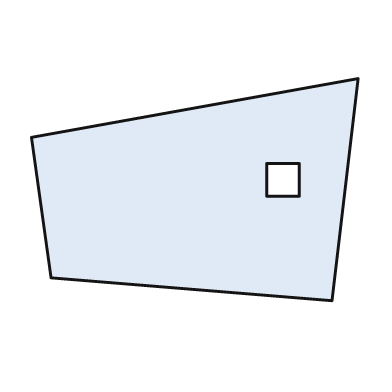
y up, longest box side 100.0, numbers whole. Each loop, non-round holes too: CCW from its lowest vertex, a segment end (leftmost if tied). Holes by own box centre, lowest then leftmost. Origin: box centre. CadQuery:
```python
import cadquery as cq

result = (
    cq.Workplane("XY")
    .moveTo(42.0, -34.0)
    .lineTo(50.0, 34.0)
    .lineTo(-50.0, 16.0)
    .lineTo(-44.0, -27.0)
    .close()
    .moveTo(22.0, -2.0)
    .lineTo(32.0, -2.0)
    .lineTo(32.0, 8.0)
    .lineTo(22.0, 8.0)
    .close()
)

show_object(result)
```